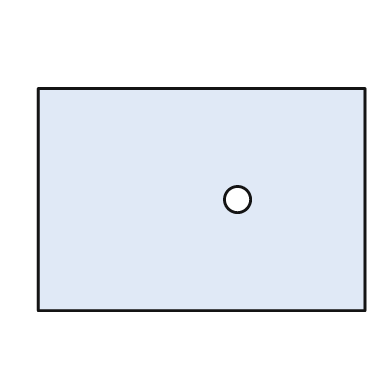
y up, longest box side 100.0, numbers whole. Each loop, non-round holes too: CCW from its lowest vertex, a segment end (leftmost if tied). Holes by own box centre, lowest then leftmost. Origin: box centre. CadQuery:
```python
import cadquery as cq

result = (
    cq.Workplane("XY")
    .moveTo(-50.0, -34.0)
    .lineTo(50.0, -34.0)
    .lineTo(50.0, 34.0)
    .lineTo(-50.0, 34.0)
    .close()
    .moveTo(11.0, 0.0)
    .circle(4.0)
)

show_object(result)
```